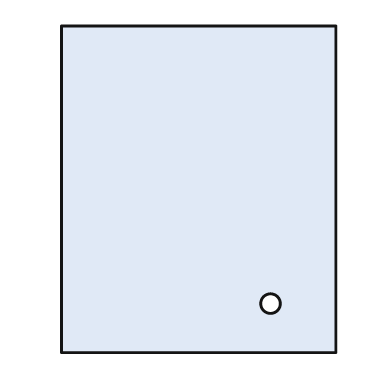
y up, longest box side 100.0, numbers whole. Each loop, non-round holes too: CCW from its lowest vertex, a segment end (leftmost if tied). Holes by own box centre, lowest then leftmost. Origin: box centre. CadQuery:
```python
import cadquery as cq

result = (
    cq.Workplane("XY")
    .moveTo(-42.0, -50.0)
    .lineTo(42.0, -50.0)
    .lineTo(42.0, 50.0)
    .lineTo(-42.0, 50.0)
    .close()
    .moveTo(22.0, -35.0)
    .circle(3.0)
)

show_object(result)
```